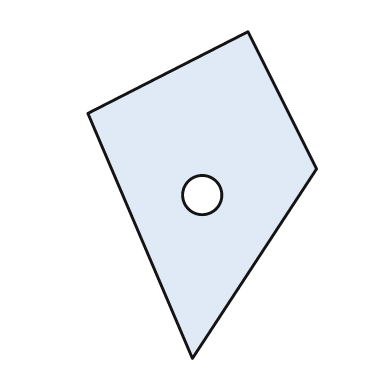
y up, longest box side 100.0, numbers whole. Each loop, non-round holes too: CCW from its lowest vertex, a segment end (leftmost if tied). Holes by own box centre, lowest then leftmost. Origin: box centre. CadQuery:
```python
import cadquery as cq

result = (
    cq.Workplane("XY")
    .moveTo(-3.0, -50.0)
    .lineTo(35.0, 8.0)
    .lineTo(14.0, 50.0)
    .lineTo(-35.0, 25.0)
    .close()
    .moveTo(0.0, 0.0)
    .circle(6.0)
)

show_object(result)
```